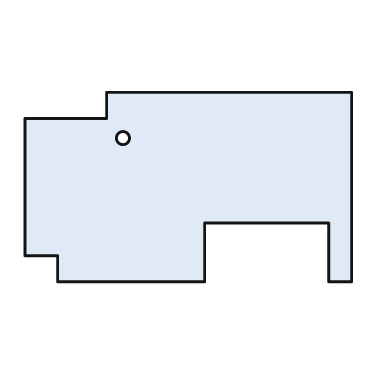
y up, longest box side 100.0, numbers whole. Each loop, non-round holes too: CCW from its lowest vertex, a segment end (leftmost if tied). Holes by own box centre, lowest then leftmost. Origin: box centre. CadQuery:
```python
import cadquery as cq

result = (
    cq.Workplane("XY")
    .moveTo(-40.0, -29.0)
    .lineTo(5.0, -29.0)
    .lineTo(5.0, -11.0)
    .lineTo(43.0, -11.0)
    .lineTo(43.0, -29.0)
    .lineTo(50.0, -29.0)
    .lineTo(50.0, 29.0)
    .lineTo(-25.0, 29.0)
    .lineTo(-25.0, 21.0)
    .lineTo(-50.0, 21.0)
    .lineTo(-50.0, -21.0)
    .lineTo(-40.0, -21.0)
    .close()
    .moveTo(-20.0, 15.0)
    .circle(2.0)
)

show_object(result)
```